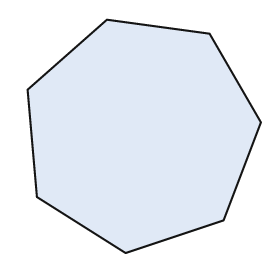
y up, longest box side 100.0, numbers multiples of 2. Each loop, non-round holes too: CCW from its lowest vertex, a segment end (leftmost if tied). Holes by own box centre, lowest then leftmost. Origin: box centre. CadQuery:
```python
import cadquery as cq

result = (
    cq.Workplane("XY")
    .moveTo(-8.0, -50.0)
    .lineTo(34.0, -36.0)
    .lineTo(50.0, 6.0)
    .lineTo(28.0, 44.0)
    .lineTo(-16.0, 50.0)
    .lineTo(-50.0, 20.0)
    .lineTo(-46.0, -26.0)
    .close()
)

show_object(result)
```